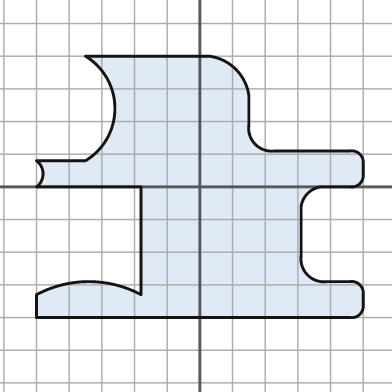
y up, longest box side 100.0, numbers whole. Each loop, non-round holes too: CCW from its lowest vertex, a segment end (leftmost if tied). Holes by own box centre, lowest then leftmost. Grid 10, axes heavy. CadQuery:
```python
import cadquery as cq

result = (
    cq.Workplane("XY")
    .moveTo(-50.0, -40.0)
    .lineTo(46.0, -40.0)
    .threePointArc((49.0, -39.0), (50.0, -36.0))
    .lineTo(50.0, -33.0)
    .threePointArc((49.0, -30.0), (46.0, -29.0))
    .lineTo(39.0, -29.0)
    .threePointArc((33.0, -27.0), (31.0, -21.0))
    .lineTo(31.0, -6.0)
    .threePointArc((33.0, -2.0), (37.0, 0.0))
    .lineTo(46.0, 0.0)
    .threePointArc((49.0, 1.0), (50.0, 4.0))
    .lineTo(50.0, 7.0)
    .threePointArc((49.0, 10.0), (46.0, 11.0))
    .lineTo(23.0, 11.0)
    .threePointArc((17.0, 13.0), (15.0, 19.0))
    .lineTo(15.0, 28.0)
    .threePointArc((11.0, 36.0), (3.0, 40.0))
    .lineTo(-35.0, 40.0)
    .threePointArc((-26.0, 24.0), (-35.0, 8.0))
    .lineTo(-50.0, 8.0)
    .threePointArc((-48.0, 4.0), (-50.0, 0.0))
    .lineTo(-18.0, 0.0)
    .lineTo(-18.0, -33.0)
    .threePointArc((-34.0, -29.0), (-50.0, -33.0))
    .close()
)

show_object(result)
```